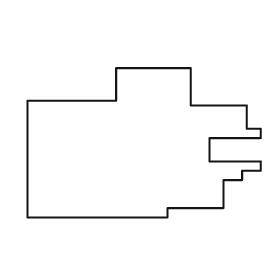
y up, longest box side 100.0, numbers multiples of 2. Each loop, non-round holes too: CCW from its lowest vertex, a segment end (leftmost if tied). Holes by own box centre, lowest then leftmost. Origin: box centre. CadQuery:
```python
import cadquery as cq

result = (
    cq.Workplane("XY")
    .moveTo(-50.0, -32.0)
    .lineTo(10.0, -32.0)
    .lineTo(10.0, -28.0)
    .lineTo(34.0, -28.0)
    .lineTo(34.0, -16.0)
    .lineTo(42.0, -16.0)
    .lineTo(42.0, -12.0)
    .lineTo(50.0, -12.0)
    .lineTo(50.0, -8.0)
    .lineTo(28.0, -8.0)
    .lineTo(28.0, 2.0)
    .lineTo(50.0, 2.0)
    .lineTo(50.0, 6.0)
    .lineTo(44.0, 6.0)
    .lineTo(44.0, 16.0)
    .lineTo(20.0, 16.0)
    .lineTo(20.0, 32.0)
    .lineTo(-12.0, 32.0)
    .lineTo(-12.0, 18.0)
    .lineTo(-50.0, 18.0)
    .close()
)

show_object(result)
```